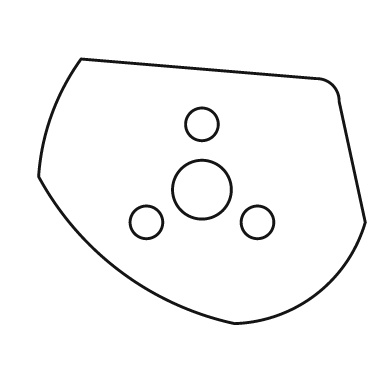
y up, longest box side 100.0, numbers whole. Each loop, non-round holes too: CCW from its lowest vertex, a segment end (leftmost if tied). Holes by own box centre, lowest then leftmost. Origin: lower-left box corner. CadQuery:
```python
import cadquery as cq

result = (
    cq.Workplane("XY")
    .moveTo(60.0, 0.0)
    .threePointArc((85.0, 9.0), (100.0, 31.0))
    .lineTo(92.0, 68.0)
    .threePointArc((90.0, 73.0), (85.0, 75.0))
    .lineTo(13.0, 81.0)
    .threePointArc((4.0, 64.0), (0.0, 45.0))
    .threePointArc((25.0, 16.0), (60.0, 0.0))
    .close()
    .moveTo(33.0, 31.0)
    .circle(5.0)
    .moveTo(67.0, 31.0)
    .circle(5.0)
    .moveTo(50.0, 41.0)
    .circle(9.0)
    .moveTo(50.0, 61.0)
    .circle(5.0)
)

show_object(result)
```